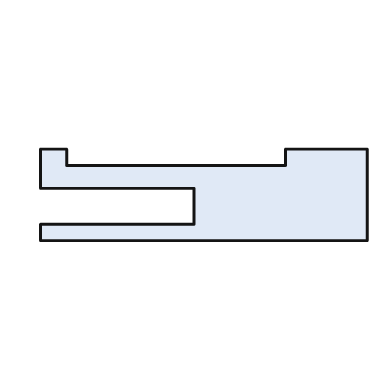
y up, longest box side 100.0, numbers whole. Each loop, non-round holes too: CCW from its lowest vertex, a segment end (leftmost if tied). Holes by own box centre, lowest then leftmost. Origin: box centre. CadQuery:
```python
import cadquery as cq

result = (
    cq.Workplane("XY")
    .moveTo(-50.0, -14.0)
    .lineTo(50.0, -14.0)
    .lineTo(50.0, 14.0)
    .lineTo(25.0, 14.0)
    .lineTo(25.0, 9.0)
    .lineTo(-42.0, 9.0)
    .lineTo(-42.0, 14.0)
    .lineTo(-50.0, 14.0)
    .lineTo(-50.0, 2.0)
    .lineTo(-3.0, 2.0)
    .lineTo(-3.0, -9.0)
    .lineTo(-50.0, -9.0)
    .close()
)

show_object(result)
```